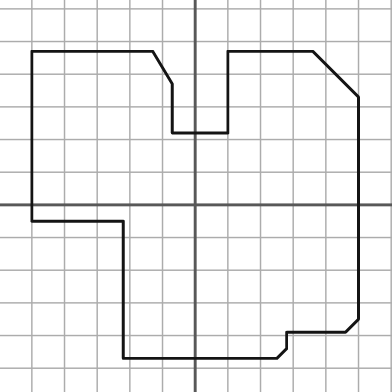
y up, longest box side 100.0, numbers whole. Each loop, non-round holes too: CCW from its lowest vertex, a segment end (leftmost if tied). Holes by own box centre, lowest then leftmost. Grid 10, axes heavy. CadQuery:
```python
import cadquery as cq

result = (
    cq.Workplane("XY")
    .moveTo(-22.0, -47.0)
    .lineTo(25.0, -47.0)
    .lineTo(28.0, -44.0)
    .lineTo(28.0, -39.0)
    .lineTo(46.0, -39.0)
    .lineTo(50.0, -35.0)
    .lineTo(50.0, 33.0)
    .lineTo(36.0, 47.0)
    .lineTo(10.0, 47.0)
    .lineTo(10.0, 22.0)
    .lineTo(-7.0, 22.0)
    .lineTo(-7.0, 37.0)
    .lineTo(-13.0, 47.0)
    .lineTo(-50.0, 47.0)
    .lineTo(-50.0, -5.0)
    .lineTo(-22.0, -5.0)
    .close()
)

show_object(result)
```